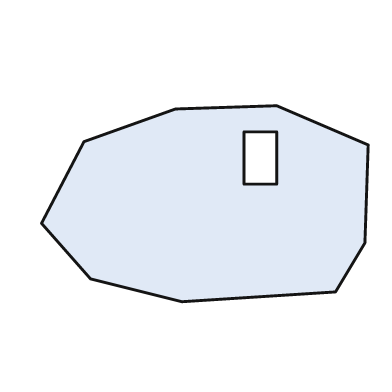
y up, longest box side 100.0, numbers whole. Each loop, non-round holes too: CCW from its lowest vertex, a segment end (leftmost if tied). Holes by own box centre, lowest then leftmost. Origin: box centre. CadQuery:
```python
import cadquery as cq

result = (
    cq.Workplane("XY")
    .moveTo(-7.0, -30.0)
    .lineTo(40.0, -27.0)
    .lineTo(49.0, -12.0)
    .lineTo(50.0, 18.0)
    .lineTo(22.0, 30.0)
    .lineTo(-9.0, 29.0)
    .lineTo(-37.0, 19.0)
    .lineTo(-50.0, -6.0)
    .lineTo(-35.0, -23.0)
    .close()
    .moveTo(12.0, 6.0)
    .lineTo(22.0, 6.0)
    .lineTo(22.0, 22.0)
    .lineTo(12.0, 22.0)
    .close()
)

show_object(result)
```